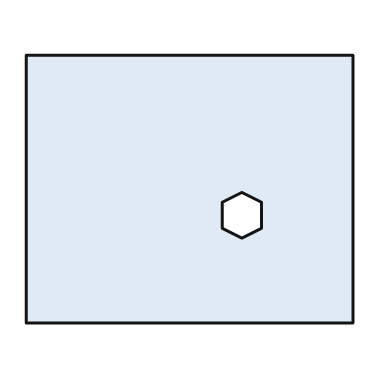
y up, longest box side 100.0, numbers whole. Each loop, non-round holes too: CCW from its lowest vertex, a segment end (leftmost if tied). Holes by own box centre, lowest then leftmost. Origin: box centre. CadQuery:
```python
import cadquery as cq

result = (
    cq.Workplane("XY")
    .moveTo(-50.0, -41.0)
    .lineTo(50.0, -41.0)
    .lineTo(50.0, 41.0)
    .lineTo(-50.0, 41.0)
    .close()
    .moveTo(16.0, -15.0)
    .lineTo(22.0, -12.0)
    .lineTo(22.0, -4.0)
    .lineTo(16.0, -1.0)
    .lineTo(10.0, -4.0)
    .lineTo(10.0, -12.0)
    .close()
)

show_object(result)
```